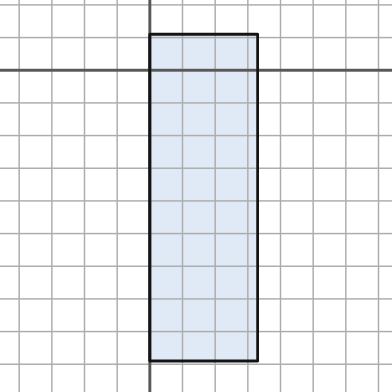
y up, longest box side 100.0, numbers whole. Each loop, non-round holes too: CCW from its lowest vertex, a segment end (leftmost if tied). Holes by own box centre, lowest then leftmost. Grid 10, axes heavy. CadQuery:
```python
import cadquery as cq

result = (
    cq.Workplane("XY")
    .moveTo(0.0, -89.0)
    .lineTo(33.0, -89.0)
    .lineTo(33.0, 11.0)
    .lineTo(0.0, 11.0)
    .close()
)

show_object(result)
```